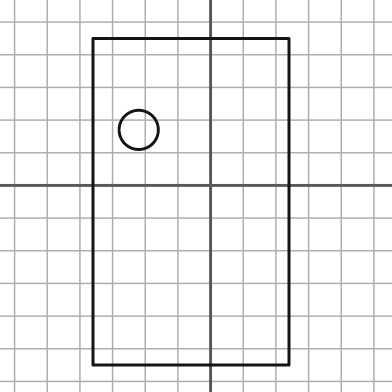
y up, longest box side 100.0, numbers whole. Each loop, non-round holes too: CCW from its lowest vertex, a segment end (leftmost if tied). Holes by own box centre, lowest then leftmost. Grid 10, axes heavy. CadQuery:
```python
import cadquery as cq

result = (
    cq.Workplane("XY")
    .moveTo(-36.0, -55.0)
    .lineTo(24.0, -55.0)
    .lineTo(24.0, 45.0)
    .lineTo(-36.0, 45.0)
    .close()
    .moveTo(-22.0, 17.0)
    .circle(6.0)
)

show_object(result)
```